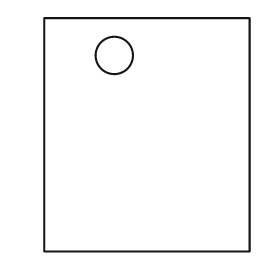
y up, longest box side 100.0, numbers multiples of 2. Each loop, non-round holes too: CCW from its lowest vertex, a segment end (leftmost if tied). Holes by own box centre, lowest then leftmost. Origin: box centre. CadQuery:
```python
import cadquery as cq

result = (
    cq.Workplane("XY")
    .moveTo(-44.0, -50.0)
    .lineTo(44.0, -50.0)
    .lineTo(44.0, 50.0)
    .lineTo(-44.0, 50.0)
    .close()
    .moveTo(-14.0, 34.0)
    .circle(8.0)
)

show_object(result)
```